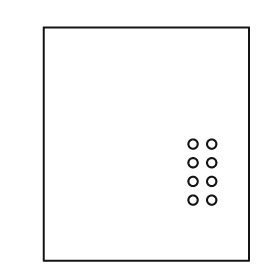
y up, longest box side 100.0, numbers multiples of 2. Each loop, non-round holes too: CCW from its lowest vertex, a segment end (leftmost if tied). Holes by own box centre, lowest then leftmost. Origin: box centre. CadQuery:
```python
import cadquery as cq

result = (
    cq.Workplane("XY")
    .moveTo(-44.0, -50.0)
    .lineTo(44.0, -50.0)
    .lineTo(44.0, 50.0)
    .lineTo(-44.0, 50.0)
    .close()
    .moveTo(20.0, -24.0)
    .circle(2.0)
    .moveTo(28.0, -24.0)
    .circle(2.0)
    .moveTo(20.0, -16.0)
    .circle(2.0)
    .moveTo(28.0, -16.0)
    .circle(2.0)
    .moveTo(20.0, -8.0)
    .circle(2.0)
    .moveTo(28.0, -8.0)
    .circle(2.0)
    .moveTo(20.0, 0.0)
    .circle(2.0)
    .moveTo(28.0, 0.0)
    .circle(2.0)
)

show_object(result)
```